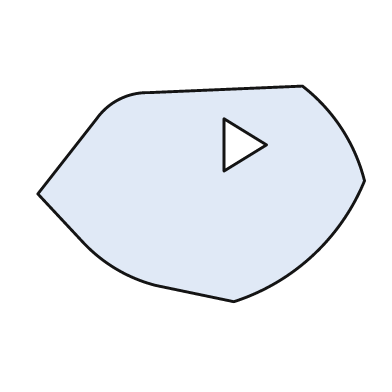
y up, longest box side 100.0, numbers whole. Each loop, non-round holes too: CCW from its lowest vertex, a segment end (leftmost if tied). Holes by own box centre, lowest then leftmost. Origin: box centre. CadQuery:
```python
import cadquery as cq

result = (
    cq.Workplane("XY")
    .moveTo(10.0, -33.0)
    .threePointArc((34.0, -19.0), (50.0, 4.0))
    .threePointArc((43.0, 20.0), (31.0, 33.0))
    .lineTo(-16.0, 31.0)
    .threePointArc((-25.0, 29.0), (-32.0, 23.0))
    .lineTo(-50.0, 0.0)
    .lineTo(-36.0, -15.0)
    .threePointArc((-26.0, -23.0), (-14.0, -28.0))
    .close()
    .moveTo(7.0, 7.0)
    .lineTo(20.0, 15.0)
    .lineTo(7.0, 23.0)
    .close()
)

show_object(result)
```